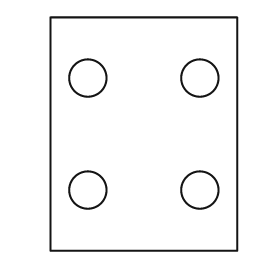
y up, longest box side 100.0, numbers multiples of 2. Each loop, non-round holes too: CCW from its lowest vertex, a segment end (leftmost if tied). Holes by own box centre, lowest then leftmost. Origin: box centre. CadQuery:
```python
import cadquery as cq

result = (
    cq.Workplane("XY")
    .moveTo(-40.0, -50.0)
    .lineTo(40.0, -50.0)
    .lineTo(40.0, 50.0)
    .lineTo(-40.0, 50.0)
    .close()
    .moveTo(-24.0, -24.0)
    .circle(8.0)
    .moveTo(24.0, -24.0)
    .circle(8.0)
    .moveTo(-24.0, 24.0)
    .circle(8.0)
    .moveTo(24.0, 24.0)
    .circle(8.0)
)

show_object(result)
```